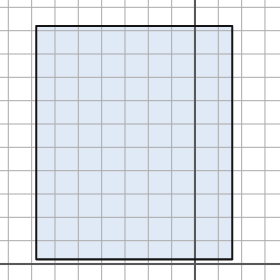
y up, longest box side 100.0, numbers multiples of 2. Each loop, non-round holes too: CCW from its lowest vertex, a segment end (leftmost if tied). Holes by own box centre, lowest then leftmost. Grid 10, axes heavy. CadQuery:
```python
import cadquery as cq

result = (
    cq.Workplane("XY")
    .moveTo(-68.0, 2.0)
    .lineTo(16.0, 2.0)
    .lineTo(16.0, 102.0)
    .lineTo(-68.0, 102.0)
    .close()
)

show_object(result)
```